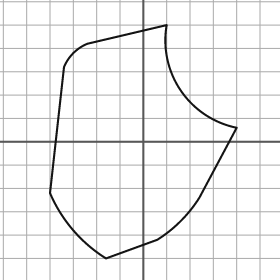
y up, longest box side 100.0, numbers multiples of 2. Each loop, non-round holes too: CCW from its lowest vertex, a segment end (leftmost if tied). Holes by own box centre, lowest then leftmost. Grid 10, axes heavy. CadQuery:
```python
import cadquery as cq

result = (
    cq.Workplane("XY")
    .moveTo(-16.0, -50.0)
    .lineTo(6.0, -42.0)
    .threePointArc((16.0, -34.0), (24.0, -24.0))
    .lineTo(40.0, 6.0)
    .threePointArc((16.0, 22.0), (10.0, 50.0))
    .lineTo(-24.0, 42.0)
    .threePointArc((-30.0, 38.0), (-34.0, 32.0))
    .lineTo(-40.0, -22.0)
    .threePointArc((-30.0, -38.0), (-16.0, -50.0))
    .close()
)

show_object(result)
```